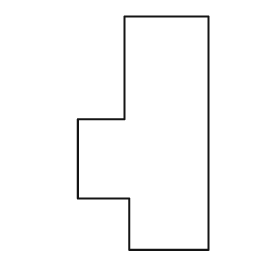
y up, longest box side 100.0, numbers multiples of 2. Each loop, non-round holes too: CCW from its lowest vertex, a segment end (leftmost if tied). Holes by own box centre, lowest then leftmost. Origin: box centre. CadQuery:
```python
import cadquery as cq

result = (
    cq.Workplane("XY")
    .moveTo(-6.0, -50.0)
    .lineTo(28.0, -50.0)
    .lineTo(28.0, 50.0)
    .lineTo(-8.0, 50.0)
    .lineTo(-8.0, 6.0)
    .lineTo(-28.0, 6.0)
    .lineTo(-28.0, -28.0)
    .lineTo(-6.0, -28.0)
    .close()
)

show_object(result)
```